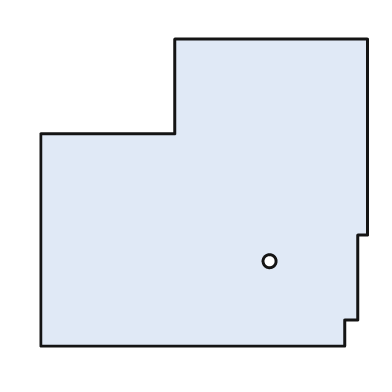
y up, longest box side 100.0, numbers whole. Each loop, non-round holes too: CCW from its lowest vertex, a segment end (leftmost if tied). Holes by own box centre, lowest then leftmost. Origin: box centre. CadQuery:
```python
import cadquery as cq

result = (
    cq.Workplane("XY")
    .moveTo(-50.0, -47.0)
    .lineTo(43.0, -47.0)
    .lineTo(43.0, -39.0)
    .lineTo(47.0, -39.0)
    .lineTo(47.0, -13.0)
    .lineTo(50.0, -13.0)
    .lineTo(50.0, 47.0)
    .lineTo(-9.0, 47.0)
    .lineTo(-9.0, 18.0)
    .lineTo(-50.0, 18.0)
    .close()
    .moveTo(20.0, -21.0)
    .circle(2.0)
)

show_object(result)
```